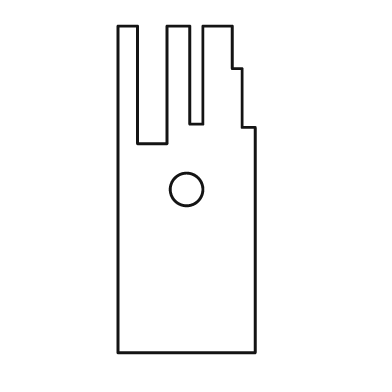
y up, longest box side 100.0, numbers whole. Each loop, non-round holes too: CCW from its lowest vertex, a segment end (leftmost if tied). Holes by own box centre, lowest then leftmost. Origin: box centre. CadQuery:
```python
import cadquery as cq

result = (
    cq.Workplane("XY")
    .moveTo(-21.0, -50.0)
    .lineTo(21.0, -50.0)
    .lineTo(21.0, 19.0)
    .lineTo(17.0, 19.0)
    .lineTo(17.0, 37.0)
    .lineTo(14.0, 37.0)
    .lineTo(14.0, 50.0)
    .lineTo(5.0, 50.0)
    .lineTo(5.0, 20.0)
    .lineTo(1.0, 20.0)
    .lineTo(1.0, 50.0)
    .lineTo(-6.0, 50.0)
    .lineTo(-6.0, 14.0)
    .lineTo(-15.0, 14.0)
    .lineTo(-15.0, 50.0)
    .lineTo(-21.0, 50.0)
    .close()
    .moveTo(0.0, 0.0)
    .circle(5.0)
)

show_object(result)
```